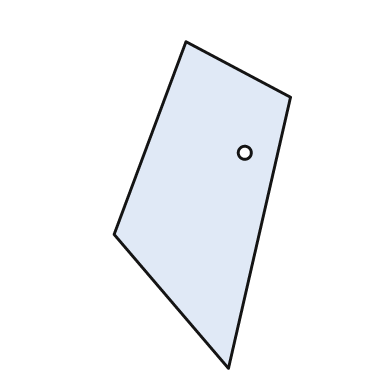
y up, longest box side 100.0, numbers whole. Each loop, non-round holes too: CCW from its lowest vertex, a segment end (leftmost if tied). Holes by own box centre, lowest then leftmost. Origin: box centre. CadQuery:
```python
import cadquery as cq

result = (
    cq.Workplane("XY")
    .moveTo(8.0, -50.0)
    .lineTo(27.0, 33.0)
    .lineTo(-5.0, 50.0)
    .lineTo(-27.0, -9.0)
    .close()
    .moveTo(13.0, 16.0)
    .circle(2.0)
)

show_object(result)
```